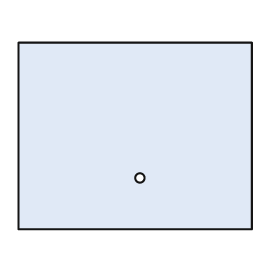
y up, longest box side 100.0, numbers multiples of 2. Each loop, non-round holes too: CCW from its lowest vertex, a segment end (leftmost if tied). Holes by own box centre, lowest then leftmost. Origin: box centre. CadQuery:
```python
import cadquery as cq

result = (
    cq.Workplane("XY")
    .moveTo(-50.0, -40.0)
    .lineTo(50.0, -40.0)
    .lineTo(50.0, 40.0)
    .lineTo(-50.0, 40.0)
    .close()
    .moveTo(2.0, -18.0)
    .circle(2.0)
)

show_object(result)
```